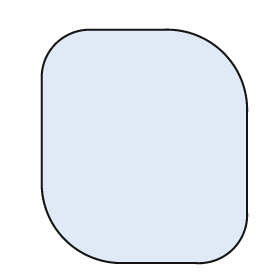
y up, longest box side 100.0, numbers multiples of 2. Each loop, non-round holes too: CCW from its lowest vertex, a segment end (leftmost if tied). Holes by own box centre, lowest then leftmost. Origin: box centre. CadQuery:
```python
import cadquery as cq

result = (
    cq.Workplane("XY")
    .moveTo(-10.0, -50.0)
    .lineTo(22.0, -50.0)
    .threePointArc((38.0, -44.0), (44.0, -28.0))
    .lineTo(44.0, 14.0)
    .threePointArc((34.0, 40.0), (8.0, 50.0))
    .lineTo(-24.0, 50.0)
    .threePointArc((-38.0, 44.0), (-44.0, 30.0))
    .lineTo(-44.0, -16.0)
    .threePointArc((-34.0, -40.0), (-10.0, -50.0))
    .close()
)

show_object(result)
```